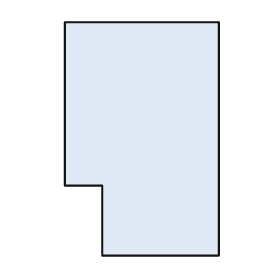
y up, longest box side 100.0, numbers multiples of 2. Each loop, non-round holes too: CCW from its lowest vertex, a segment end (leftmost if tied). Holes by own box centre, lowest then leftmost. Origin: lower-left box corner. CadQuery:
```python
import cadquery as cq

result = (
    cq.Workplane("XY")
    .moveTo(16.0, 0.0)
    .lineTo(66.0, 0.0)
    .lineTo(66.0, 100.0)
    .lineTo(0.0, 100.0)
    .lineTo(0.0, 30.0)
    .lineTo(16.0, 30.0)
    .close()
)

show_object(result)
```